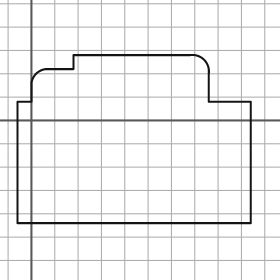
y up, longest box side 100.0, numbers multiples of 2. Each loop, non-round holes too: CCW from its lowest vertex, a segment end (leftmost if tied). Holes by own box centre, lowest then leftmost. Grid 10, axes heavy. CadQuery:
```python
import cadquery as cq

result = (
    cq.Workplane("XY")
    .moveTo(-6.0, -44.0)
    .lineTo(94.0, -44.0)
    .lineTo(94.0, 8.0)
    .lineTo(76.0, 8.0)
    .lineTo(76.0, 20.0)
    .threePointArc((74.0, 26.0), (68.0, 28.0))
    .lineTo(18.0, 28.0)
    .lineTo(18.0, 22.0)
    .lineTo(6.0, 22.0)
    .threePointArc((2.0, 20.0), (0.0, 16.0))
    .lineTo(0.0, 8.0)
    .lineTo(-6.0, 8.0)
    .close()
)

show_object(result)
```